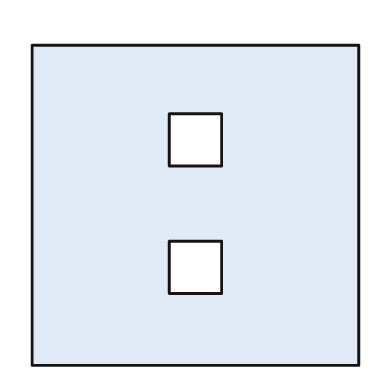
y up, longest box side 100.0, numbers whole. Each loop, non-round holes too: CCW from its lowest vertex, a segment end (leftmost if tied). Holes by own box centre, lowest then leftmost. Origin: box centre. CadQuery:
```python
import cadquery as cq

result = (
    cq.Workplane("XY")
    .moveTo(-50.0, -49.0)
    .lineTo(50.0, -49.0)
    .lineTo(50.0, 49.0)
    .lineTo(-50.0, 49.0)
    .close()
    .moveTo(-8.0, -27.0)
    .lineTo(8.0, -27.0)
    .lineTo(8.0, -11.0)
    .lineTo(-8.0, -11.0)
    .close()
    .moveTo(-8.0, 12.0)
    .lineTo(8.0, 12.0)
    .lineTo(8.0, 28.0)
    .lineTo(-8.0, 28.0)
    .close()
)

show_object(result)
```